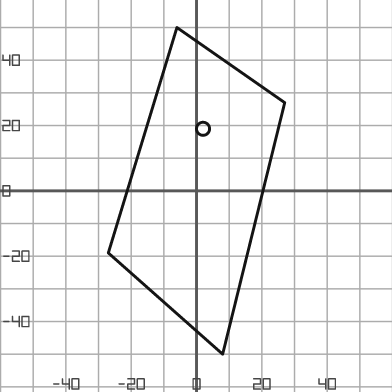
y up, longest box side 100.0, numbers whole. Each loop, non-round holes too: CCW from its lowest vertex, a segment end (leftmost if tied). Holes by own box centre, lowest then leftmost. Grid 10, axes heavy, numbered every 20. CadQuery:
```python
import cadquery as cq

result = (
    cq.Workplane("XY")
    .moveTo(8.0, -50.0)
    .lineTo(27.0, 27.0)
    .lineTo(-6.0, 50.0)
    .lineTo(-27.0, -19.0)
    .close()
    .moveTo(2.0, 19.0)
    .circle(2.0)
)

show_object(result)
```